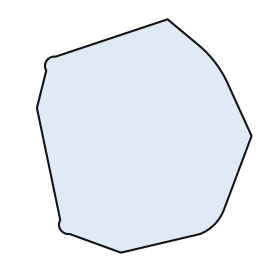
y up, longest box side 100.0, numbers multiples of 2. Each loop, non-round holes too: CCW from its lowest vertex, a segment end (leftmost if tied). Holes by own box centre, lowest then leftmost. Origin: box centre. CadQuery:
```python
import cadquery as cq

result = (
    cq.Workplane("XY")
    .moveTo(-10.0, -50.0)
    .lineTo(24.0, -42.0)
    .threePointArc((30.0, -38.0), (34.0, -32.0))
    .lineTo(46.0, 0.0)
    .lineTo(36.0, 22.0)
    .threePointArc((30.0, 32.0), (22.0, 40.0))
    .lineTo(10.0, 50.0)
    .lineTo(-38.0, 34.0)
    .threePointArc((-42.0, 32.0), (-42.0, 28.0))
    .lineTo(-46.0, 12.0)
    .lineTo(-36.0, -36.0)
    .threePointArc((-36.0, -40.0), (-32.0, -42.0))
    .close()
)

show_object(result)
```